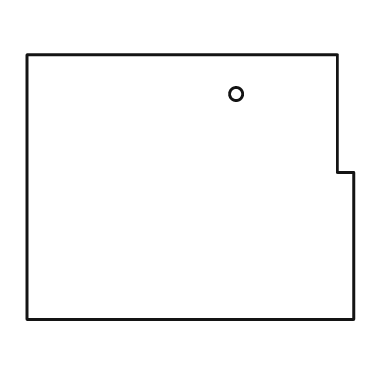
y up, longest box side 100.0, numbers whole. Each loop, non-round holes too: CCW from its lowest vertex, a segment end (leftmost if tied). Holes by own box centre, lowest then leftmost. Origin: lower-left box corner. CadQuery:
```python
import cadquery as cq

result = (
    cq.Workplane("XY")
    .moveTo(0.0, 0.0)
    .lineTo(100.0, 0.0)
    .lineTo(100.0, 45.0)
    .lineTo(95.0, 45.0)
    .lineTo(95.0, 81.0)
    .lineTo(0.0, 81.0)
    .close()
    .moveTo(64.0, 69.0)
    .circle(2.0)
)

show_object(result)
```